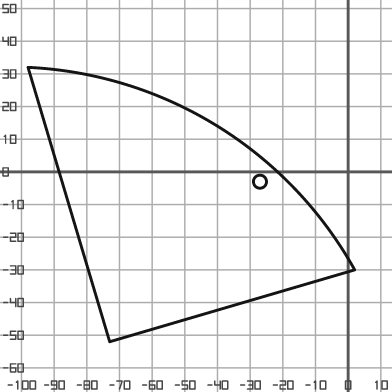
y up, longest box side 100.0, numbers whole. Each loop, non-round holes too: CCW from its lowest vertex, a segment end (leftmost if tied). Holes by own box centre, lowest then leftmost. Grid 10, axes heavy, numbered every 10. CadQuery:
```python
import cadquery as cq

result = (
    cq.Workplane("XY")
    .moveTo(-73.0, -52.0)
    .lineTo(2.0, -30.0)
    .threePointArc((-40.0, 14.0), (-98.0, 32.0))
    .close()
    .moveTo(-27.0, -3.0)
    .circle(2.0)
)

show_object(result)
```